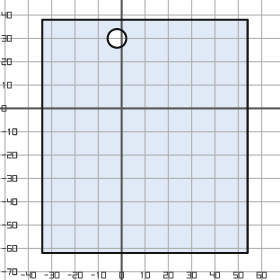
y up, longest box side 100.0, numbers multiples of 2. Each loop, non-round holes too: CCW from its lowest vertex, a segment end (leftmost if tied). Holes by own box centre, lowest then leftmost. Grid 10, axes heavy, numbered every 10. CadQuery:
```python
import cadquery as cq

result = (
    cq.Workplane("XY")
    .moveTo(-34.0, -62.0)
    .lineTo(54.0, -62.0)
    .lineTo(54.0, 38.0)
    .lineTo(-34.0, 38.0)
    .close()
    .moveTo(-2.0, 30.0)
    .circle(4.0)
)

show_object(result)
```